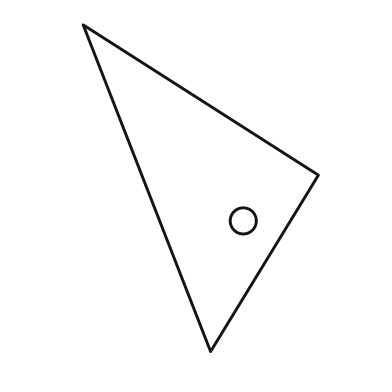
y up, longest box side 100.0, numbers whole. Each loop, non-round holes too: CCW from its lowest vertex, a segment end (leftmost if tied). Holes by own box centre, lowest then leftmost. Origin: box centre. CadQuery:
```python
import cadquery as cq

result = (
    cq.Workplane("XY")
    .moveTo(3.0, -50.0)
    .lineTo(36.0, 4.0)
    .lineTo(-36.0, 50.0)
    .close()
    .moveTo(13.0, -10.0)
    .circle(4.0)
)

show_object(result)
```